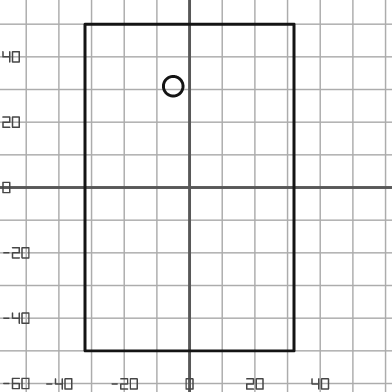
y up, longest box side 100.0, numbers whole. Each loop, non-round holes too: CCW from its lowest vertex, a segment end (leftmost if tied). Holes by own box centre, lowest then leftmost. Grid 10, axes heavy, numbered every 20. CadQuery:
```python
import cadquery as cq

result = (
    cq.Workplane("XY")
    .moveTo(-32.0, -50.0)
    .lineTo(32.0, -50.0)
    .lineTo(32.0, 50.0)
    .lineTo(-32.0, 50.0)
    .close()
    .moveTo(-5.0, 31.0)
    .circle(3.0)
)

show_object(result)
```